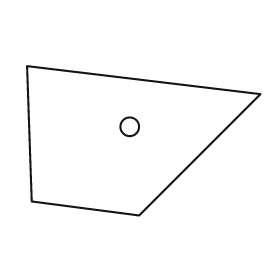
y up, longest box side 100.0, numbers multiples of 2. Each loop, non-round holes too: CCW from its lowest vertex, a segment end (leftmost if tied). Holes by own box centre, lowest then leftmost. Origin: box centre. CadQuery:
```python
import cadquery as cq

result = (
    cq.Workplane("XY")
    .moveTo(-2.0, -32.0)
    .lineTo(50.0, 20.0)
    .lineTo(-50.0, 32.0)
    .lineTo(-48.0, -26.0)
    .close()
    .moveTo(-6.0, 6.0)
    .circle(4.0)
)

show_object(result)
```